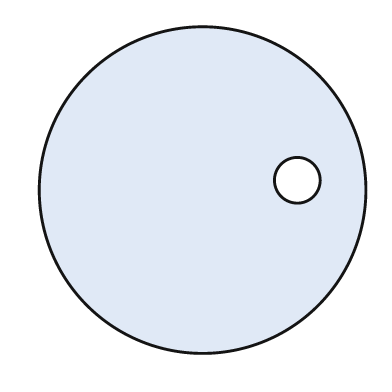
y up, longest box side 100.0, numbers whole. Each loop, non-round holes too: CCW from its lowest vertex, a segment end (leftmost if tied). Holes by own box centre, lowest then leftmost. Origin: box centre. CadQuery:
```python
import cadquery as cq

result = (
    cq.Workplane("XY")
    .moveTo(0.0, 0.0)
    .circle(50.0)
    .moveTo(29.0, 3.0)
    .circle(7.0)
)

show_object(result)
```